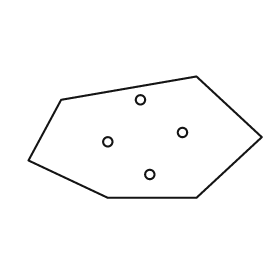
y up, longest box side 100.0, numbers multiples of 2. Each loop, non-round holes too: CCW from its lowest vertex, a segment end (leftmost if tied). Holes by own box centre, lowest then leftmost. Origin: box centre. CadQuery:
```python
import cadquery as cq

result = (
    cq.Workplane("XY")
    .moveTo(-16.0, -26.0)
    .lineTo(22.0, -26.0)
    .lineTo(50.0, 0.0)
    .lineTo(22.0, 26.0)
    .lineTo(-36.0, 16.0)
    .lineTo(-50.0, -10.0)
    .close()
    .moveTo(2.0, -16.0)
    .circle(2.0)
    .moveTo(-16.0, -2.0)
    .circle(2.0)
    .moveTo(16.0, 2.0)
    .circle(2.0)
    .moveTo(-2.0, 16.0)
    .circle(2.0)
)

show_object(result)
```